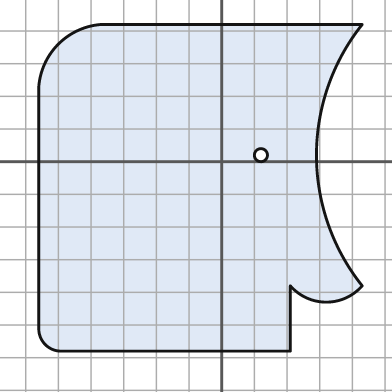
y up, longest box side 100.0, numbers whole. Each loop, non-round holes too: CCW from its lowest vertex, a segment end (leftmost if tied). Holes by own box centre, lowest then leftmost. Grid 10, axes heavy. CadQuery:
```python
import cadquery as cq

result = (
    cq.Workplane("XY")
    .moveTo(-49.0, -58.0)
    .lineTo(21.0, -58.0)
    .lineTo(21.0, -38.0)
    .threePointArc((32.0, -43.0), (43.0, -38.0))
    .threePointArc((29.0, 2.0), (43.0, 42.0))
    .lineTo(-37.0, 42.0)
    .threePointArc((-50.0, 36.0), (-56.0, 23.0))
    .lineTo(-56.0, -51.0)
    .threePointArc((-54.0, -56.0), (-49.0, -58.0))
    .close()
    .moveTo(12.0, 2.0)
    .circle(2.0)
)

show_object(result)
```